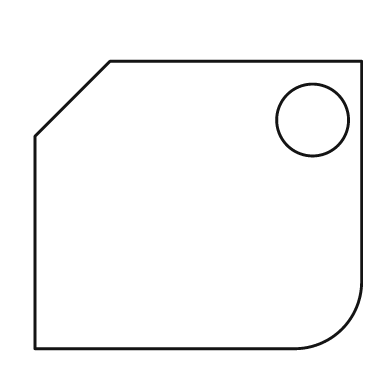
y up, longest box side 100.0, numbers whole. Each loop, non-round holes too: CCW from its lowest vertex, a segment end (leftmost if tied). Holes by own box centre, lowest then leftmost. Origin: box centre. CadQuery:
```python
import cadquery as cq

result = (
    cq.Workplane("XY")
    .moveTo(-50.0, -44.0)
    .lineTo(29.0, -44.0)
    .threePointArc((44.0, -38.0), (50.0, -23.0))
    .lineTo(50.0, 44.0)
    .lineTo(-27.0, 44.0)
    .lineTo(-50.0, 21.0)
    .close()
    .moveTo(35.0, 26.0)
    .circle(11.0)
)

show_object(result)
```